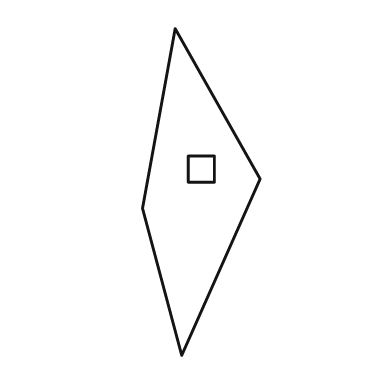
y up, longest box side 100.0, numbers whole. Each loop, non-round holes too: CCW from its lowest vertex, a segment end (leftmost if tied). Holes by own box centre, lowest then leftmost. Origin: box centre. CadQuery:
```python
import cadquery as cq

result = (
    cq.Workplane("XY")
    .moveTo(-6.0, -50.0)
    .lineTo(18.0, 4.0)
    .lineTo(-8.0, 50.0)
    .lineTo(-18.0, -5.0)
    .close()
    .moveTo(-4.0, 3.0)
    .lineTo(4.0, 3.0)
    .lineTo(4.0, 11.0)
    .lineTo(-4.0, 11.0)
    .close()
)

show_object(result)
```